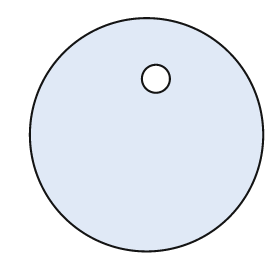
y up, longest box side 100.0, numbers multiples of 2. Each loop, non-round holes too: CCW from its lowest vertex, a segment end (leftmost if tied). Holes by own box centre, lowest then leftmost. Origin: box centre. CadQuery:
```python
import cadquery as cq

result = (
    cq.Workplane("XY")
    .moveTo(0.0, 0.0)
    .circle(50.0)
    .moveTo(4.0, 24.0)
    .circle(6.0)
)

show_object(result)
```